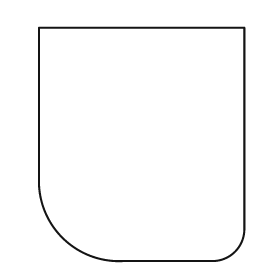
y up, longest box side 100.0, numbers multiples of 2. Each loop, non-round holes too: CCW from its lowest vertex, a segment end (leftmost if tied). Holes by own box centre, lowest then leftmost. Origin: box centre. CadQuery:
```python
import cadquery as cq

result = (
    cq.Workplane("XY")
    .moveTo(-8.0, -50.0)
    .lineTo(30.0, -50.0)
    .threePointArc((40.0, -46.0), (44.0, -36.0))
    .lineTo(44.0, 50.0)
    .lineTo(-44.0, 50.0)
    .lineTo(-44.0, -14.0)
    .threePointArc((-34.0, -40.0), (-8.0, -50.0))
    .close()
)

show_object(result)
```